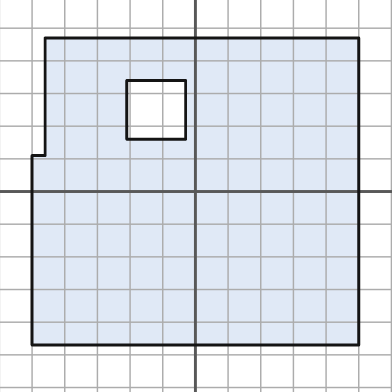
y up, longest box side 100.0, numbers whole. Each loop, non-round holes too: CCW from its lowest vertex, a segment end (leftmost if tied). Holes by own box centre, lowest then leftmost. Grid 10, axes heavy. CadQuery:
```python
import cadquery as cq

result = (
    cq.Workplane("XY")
    .moveTo(-50.0, -47.0)
    .lineTo(50.0, -47.0)
    .lineTo(50.0, 47.0)
    .lineTo(-46.0, 47.0)
    .lineTo(-46.0, 11.0)
    .lineTo(-50.0, 11.0)
    .close()
    .moveTo(-21.0, 16.0)
    .lineTo(-3.0, 16.0)
    .lineTo(-3.0, 34.0)
    .lineTo(-21.0, 34.0)
    .close()
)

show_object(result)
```